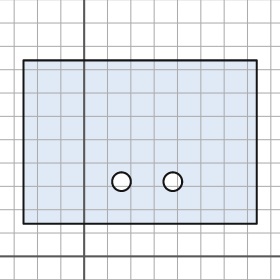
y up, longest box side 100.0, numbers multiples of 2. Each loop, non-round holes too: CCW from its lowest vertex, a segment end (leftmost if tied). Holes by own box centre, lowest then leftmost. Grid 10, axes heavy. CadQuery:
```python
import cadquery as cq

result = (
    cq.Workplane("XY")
    .moveTo(-26.0, 14.0)
    .lineTo(74.0, 14.0)
    .lineTo(74.0, 84.0)
    .lineTo(-26.0, 84.0)
    .close()
    .moveTo(16.0, 32.0)
    .circle(4.0)
    .moveTo(38.0, 32.0)
    .circle(4.0)
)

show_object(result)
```